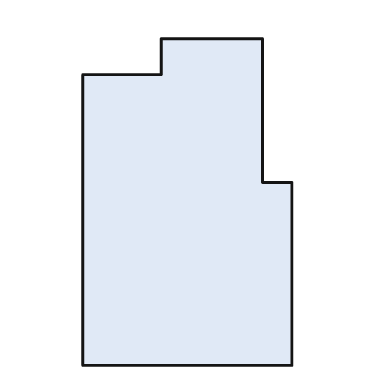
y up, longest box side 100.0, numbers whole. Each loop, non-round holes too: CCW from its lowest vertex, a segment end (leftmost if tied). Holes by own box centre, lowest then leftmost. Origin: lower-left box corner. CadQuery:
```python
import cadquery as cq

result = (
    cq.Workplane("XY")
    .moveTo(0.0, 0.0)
    .lineTo(64.0, 0.0)
    .lineTo(64.0, 56.0)
    .lineTo(55.0, 56.0)
    .lineTo(55.0, 100.0)
    .lineTo(24.0, 100.0)
    .lineTo(24.0, 89.0)
    .lineTo(0.0, 89.0)
    .close()
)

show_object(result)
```